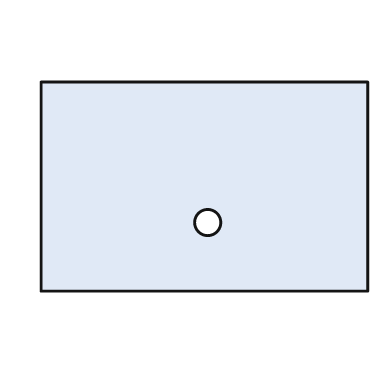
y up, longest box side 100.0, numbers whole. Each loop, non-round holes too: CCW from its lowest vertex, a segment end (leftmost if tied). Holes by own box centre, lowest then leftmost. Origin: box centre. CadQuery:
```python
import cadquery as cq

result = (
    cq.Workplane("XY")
    .moveTo(-50.0, -32.0)
    .lineTo(50.0, -32.0)
    .lineTo(50.0, 32.0)
    .lineTo(-50.0, 32.0)
    .close()
    .moveTo(1.0, -11.0)
    .circle(4.0)
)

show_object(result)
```